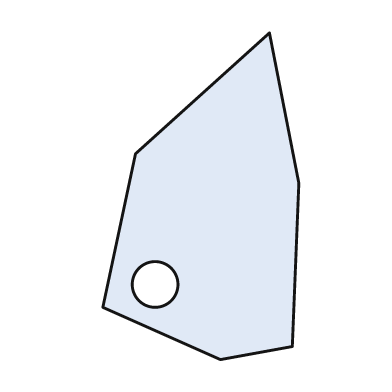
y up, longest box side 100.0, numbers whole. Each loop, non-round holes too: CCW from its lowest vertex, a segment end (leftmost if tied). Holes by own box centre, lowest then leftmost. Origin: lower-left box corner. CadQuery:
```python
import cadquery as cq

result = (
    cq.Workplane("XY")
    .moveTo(36.0, 0.0)
    .lineTo(58.0, 4.0)
    .lineTo(60.0, 54.0)
    .lineTo(51.0, 100.0)
    .lineTo(10.0, 63.0)
    .lineTo(0.0, 16.0)
    .close()
    .moveTo(16.0, 23.0)
    .circle(7.0)
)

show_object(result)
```